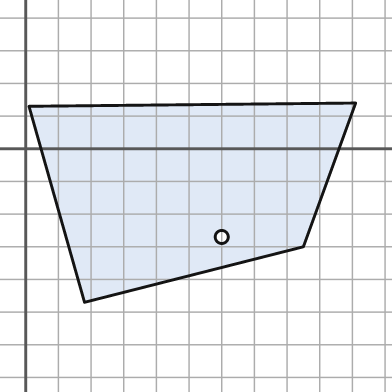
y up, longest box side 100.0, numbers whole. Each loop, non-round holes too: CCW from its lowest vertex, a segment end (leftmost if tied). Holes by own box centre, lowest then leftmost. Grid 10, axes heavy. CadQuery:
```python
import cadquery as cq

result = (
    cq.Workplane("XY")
    .moveTo(18.0, -47.0)
    .lineTo(85.0, -30.0)
    .lineTo(101.0, 14.0)
    .lineTo(1.0, 13.0)
    .close()
    .moveTo(60.0, -27.0)
    .circle(2.0)
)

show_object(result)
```